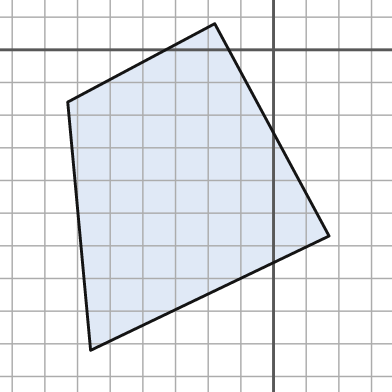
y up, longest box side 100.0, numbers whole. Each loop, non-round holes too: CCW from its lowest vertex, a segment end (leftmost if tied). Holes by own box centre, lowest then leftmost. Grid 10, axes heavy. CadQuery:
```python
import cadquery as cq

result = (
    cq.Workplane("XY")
    .moveTo(-56.0, -92.0)
    .lineTo(17.0, -57.0)
    .lineTo(-18.0, 8.0)
    .lineTo(-63.0, -16.0)
    .close()
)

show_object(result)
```